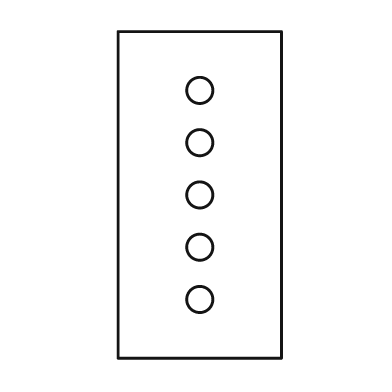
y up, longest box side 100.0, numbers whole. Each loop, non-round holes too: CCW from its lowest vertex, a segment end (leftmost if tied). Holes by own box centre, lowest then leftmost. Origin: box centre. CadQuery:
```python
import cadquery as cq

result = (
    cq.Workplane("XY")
    .moveTo(-25.0, -50.0)
    .lineTo(25.0, -50.0)
    .lineTo(25.0, 50.0)
    .lineTo(-25.0, 50.0)
    .close()
    .moveTo(0.0, -32.0)
    .circle(4.0)
    .moveTo(0.0, -16.0)
    .circle(4.0)
    .moveTo(0.0, 0.0)
    .circle(4.0)
    .moveTo(0.0, 16.0)
    .circle(4.0)
    .moveTo(0.0, 32.0)
    .circle(4.0)
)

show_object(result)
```